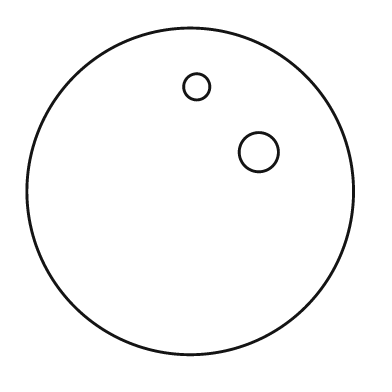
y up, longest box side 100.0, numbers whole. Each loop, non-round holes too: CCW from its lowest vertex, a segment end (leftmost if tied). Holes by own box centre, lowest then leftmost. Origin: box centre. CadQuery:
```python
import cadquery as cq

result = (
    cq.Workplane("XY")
    .moveTo(0.0, 0.0)
    .circle(50.0)
    .moveTo(21.0, 12.0)
    .circle(6.0)
    .moveTo(2.0, 32.0)
    .circle(4.0)
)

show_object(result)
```